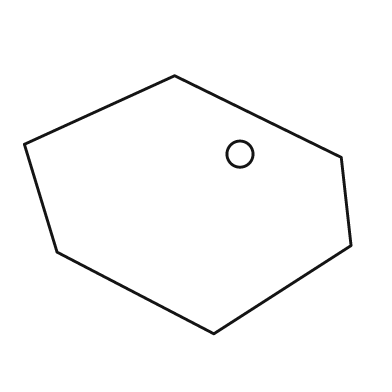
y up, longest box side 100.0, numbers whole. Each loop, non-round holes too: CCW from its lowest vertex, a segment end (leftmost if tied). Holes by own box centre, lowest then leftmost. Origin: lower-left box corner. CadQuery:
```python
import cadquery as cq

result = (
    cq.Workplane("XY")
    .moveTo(58.0, 0.0)
    .lineTo(100.0, 27.0)
    .lineTo(97.0, 54.0)
    .lineTo(46.0, 79.0)
    .lineTo(0.0, 58.0)
    .lineTo(10.0, 25.0)
    .close()
    .moveTo(66.0, 55.0)
    .circle(4.0)
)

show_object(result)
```